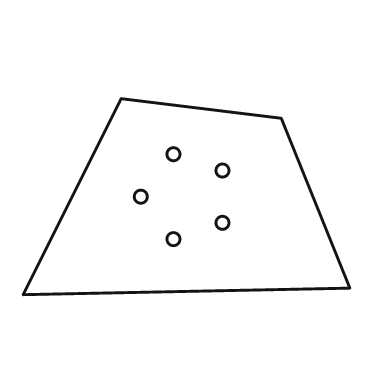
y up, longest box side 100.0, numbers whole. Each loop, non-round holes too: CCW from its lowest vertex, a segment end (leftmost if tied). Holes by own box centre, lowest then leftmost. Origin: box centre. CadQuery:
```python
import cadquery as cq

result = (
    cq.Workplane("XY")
    .moveTo(-50.0, -30.0)
    .lineTo(50.0, -28.0)
    .lineTo(29.0, 24.0)
    .lineTo(-20.0, 30.0)
    .close()
    .moveTo(-4.0, -13.0)
    .circle(2.0)
    .moveTo(11.0, -8.0)
    .circle(2.0)
    .moveTo(-14.0, 0.0)
    .circle(2.0)
    .moveTo(11.0, 8.0)
    .circle(2.0)
    .moveTo(-4.0, 13.0)
    .circle(2.0)
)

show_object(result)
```